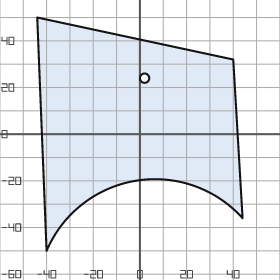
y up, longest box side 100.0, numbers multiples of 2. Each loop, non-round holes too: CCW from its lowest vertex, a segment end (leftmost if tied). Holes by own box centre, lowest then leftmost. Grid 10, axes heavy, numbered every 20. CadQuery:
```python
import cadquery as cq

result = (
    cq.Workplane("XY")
    .moveTo(-40.0, -50.0)
    .threePointArc((-2.0, -20.0), (44.0, -36.0))
    .lineTo(40.0, 32.0)
    .lineTo(-44.0, 50.0)
    .close()
    .moveTo(2.0, 24.0)
    .circle(2.0)
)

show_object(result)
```